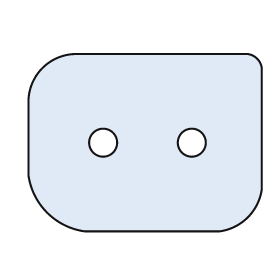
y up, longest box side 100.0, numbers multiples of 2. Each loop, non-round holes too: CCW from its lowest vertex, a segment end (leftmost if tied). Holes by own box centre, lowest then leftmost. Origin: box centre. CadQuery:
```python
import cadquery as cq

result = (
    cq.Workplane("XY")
    .moveTo(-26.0, -38.0)
    .lineTo(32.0, -38.0)
    .threePointArc((44.0, -32.0), (50.0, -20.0))
    .lineTo(50.0, 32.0)
    .threePointArc((48.0, 36.0), (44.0, 38.0))
    .lineTo(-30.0, 38.0)
    .threePointArc((-44.0, 32.0), (-50.0, 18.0))
    .lineTo(-50.0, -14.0)
    .threePointArc((-42.0, -30.0), (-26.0, -38.0))
    .close()
    .moveTo(-18.0, 0.0)
    .circle(6.0)
    .moveTo(20.0, 0.0)
    .circle(6.0)
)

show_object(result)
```